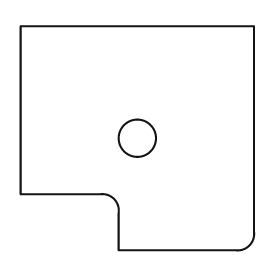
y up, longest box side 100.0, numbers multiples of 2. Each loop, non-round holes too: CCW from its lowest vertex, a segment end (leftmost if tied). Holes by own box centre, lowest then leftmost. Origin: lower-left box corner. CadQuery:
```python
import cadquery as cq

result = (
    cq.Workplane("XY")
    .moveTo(42.0, 0.0)
    .lineTo(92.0, 0.0)
    .threePointArc((98.0, 2.0), (100.0, 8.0))
    .lineTo(100.0, 96.0)
    .lineTo(0.0, 96.0)
    .lineTo(0.0, 24.0)
    .lineTo(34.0, 24.0)
    .threePointArc((40.0, 22.0), (42.0, 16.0))
    .close()
    .moveTo(50.0, 48.0)
    .circle(8.0)
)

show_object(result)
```